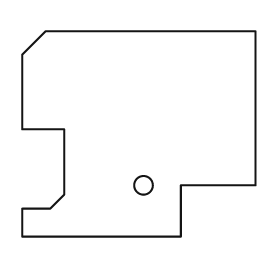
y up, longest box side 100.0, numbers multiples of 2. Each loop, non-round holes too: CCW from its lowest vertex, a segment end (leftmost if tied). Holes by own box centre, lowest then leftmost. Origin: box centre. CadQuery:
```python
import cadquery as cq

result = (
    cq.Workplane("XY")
    .moveTo(-50.0, -44.0)
    .lineTo(18.0, -44.0)
    .lineTo(18.0, -22.0)
    .lineTo(50.0, -22.0)
    .lineTo(50.0, 44.0)
    .lineTo(-40.0, 44.0)
    .lineTo(-50.0, 34.0)
    .lineTo(-50.0, 2.0)
    .lineTo(-32.0, 2.0)
    .lineTo(-32.0, -26.0)
    .lineTo(-38.0, -32.0)
    .lineTo(-50.0, -32.0)
    .close()
    .moveTo(2.0, -22.0)
    .circle(4.0)
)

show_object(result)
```